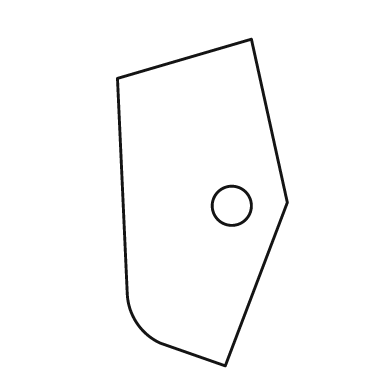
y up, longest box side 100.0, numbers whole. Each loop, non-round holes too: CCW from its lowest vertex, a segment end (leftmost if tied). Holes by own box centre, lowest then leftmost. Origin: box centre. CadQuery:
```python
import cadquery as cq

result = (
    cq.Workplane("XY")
    .moveTo(7.0, -50.0)
    .lineTo(26.0, 0.0)
    .lineTo(15.0, 50.0)
    .lineTo(-26.0, 38.0)
    .lineTo(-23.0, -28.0)
    .threePointArc((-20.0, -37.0), (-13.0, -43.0))
    .close()
    .moveTo(9.0, -1.0)
    .circle(6.0)
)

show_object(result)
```